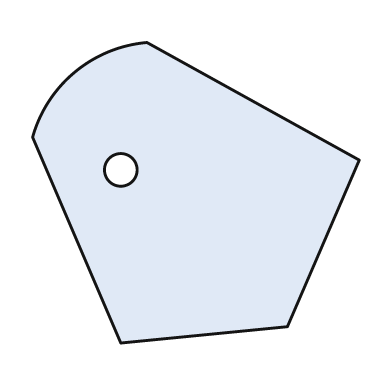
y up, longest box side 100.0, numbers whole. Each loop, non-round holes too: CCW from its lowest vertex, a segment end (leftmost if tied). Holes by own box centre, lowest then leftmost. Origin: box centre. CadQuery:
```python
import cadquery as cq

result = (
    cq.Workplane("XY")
    .moveTo(-23.0, -46.0)
    .lineTo(28.0, -41.0)
    .lineTo(50.0, 10.0)
    .lineTo(-15.0, 46.0)
    .threePointArc((-37.0, 37.0), (-50.0, 17.0))
    .close()
    .moveTo(-23.0, 7.0)
    .circle(5.0)
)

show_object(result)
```